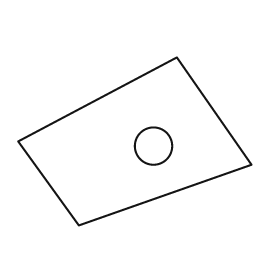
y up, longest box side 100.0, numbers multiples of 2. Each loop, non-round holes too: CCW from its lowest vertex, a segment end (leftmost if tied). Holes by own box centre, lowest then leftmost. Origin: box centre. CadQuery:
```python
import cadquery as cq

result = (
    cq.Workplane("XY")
    .moveTo(-24.0, -36.0)
    .lineTo(50.0, -10.0)
    .lineTo(18.0, 36.0)
    .lineTo(-50.0, 0.0)
    .close()
    .moveTo(8.0, -2.0)
    .circle(8.0)
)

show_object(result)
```